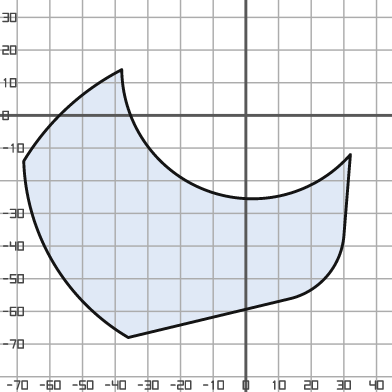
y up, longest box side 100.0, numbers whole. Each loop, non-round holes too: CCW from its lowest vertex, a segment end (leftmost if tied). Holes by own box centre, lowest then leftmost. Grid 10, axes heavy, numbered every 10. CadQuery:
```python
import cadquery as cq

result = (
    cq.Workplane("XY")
    .moveTo(-36.0, -68.0)
    .lineTo(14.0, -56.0)
    .threePointArc((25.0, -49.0), (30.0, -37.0))
    .lineTo(32.0, -12.0)
    .threePointArc((-12.0, -23.0), (-38.0, 14.0))
    .threePointArc((-55.0, 2.0), (-68.0, -14.0))
    .threePointArc((-59.0, -45.0), (-36.0, -68.0))
    .close()
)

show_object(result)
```